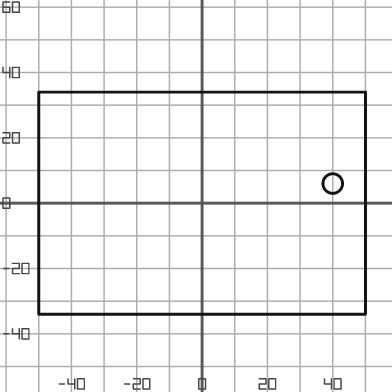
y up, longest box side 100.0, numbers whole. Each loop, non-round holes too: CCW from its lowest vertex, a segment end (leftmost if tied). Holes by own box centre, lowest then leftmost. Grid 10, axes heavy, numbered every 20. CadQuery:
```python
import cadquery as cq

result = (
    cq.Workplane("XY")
    .moveTo(-50.0, -34.0)
    .lineTo(50.0, -34.0)
    .lineTo(50.0, 34.0)
    .lineTo(-50.0, 34.0)
    .close()
    .moveTo(40.0, 6.0)
    .circle(3.0)
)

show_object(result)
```